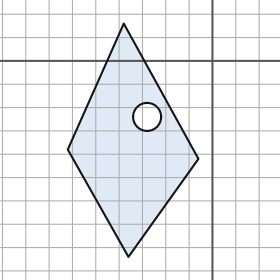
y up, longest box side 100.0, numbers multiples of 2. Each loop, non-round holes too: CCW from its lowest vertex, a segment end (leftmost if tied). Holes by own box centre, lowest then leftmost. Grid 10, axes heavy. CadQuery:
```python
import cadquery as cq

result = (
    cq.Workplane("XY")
    .moveTo(-36.0, -84.0)
    .lineTo(-6.0, -42.0)
    .lineTo(-38.0, 16.0)
    .lineTo(-62.0, -38.0)
    .close()
    .moveTo(-28.0, -24.0)
    .circle(6.0)
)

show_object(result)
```